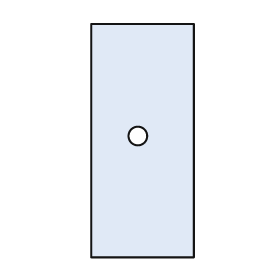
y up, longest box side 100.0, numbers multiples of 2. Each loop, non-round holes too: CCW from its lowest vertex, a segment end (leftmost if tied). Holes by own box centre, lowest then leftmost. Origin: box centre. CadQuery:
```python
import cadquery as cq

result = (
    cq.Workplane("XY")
    .moveTo(-22.0, -50.0)
    .lineTo(22.0, -50.0)
    .lineTo(22.0, 50.0)
    .lineTo(-22.0, 50.0)
    .close()
    .moveTo(-2.0, 2.0)
    .circle(4.0)
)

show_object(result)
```